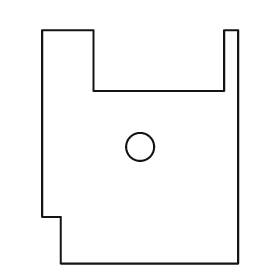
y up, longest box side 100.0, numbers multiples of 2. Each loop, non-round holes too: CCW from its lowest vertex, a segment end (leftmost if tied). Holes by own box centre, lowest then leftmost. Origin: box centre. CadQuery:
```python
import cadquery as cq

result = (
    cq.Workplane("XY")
    .moveTo(-34.0, -50.0)
    .lineTo(42.0, -50.0)
    .lineTo(42.0, 50.0)
    .lineTo(36.0, 50.0)
    .lineTo(36.0, 24.0)
    .lineTo(-20.0, 24.0)
    .lineTo(-20.0, 50.0)
    .lineTo(-42.0, 50.0)
    .lineTo(-42.0, -30.0)
    .lineTo(-34.0, -30.0)
    .close()
    .moveTo(0.0, 0.0)
    .circle(6.0)
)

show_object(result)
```